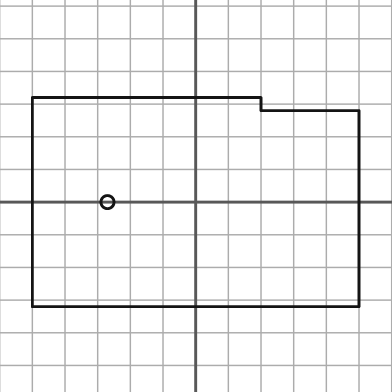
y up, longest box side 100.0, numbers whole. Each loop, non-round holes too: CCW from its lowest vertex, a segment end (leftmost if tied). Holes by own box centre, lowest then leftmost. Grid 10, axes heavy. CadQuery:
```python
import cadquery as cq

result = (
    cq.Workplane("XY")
    .moveTo(-50.0, -32.0)
    .lineTo(50.0, -32.0)
    .lineTo(50.0, 28.0)
    .lineTo(20.0, 28.0)
    .lineTo(20.0, 32.0)
    .lineTo(-50.0, 32.0)
    .close()
    .moveTo(-27.0, 0.0)
    .circle(2.0)
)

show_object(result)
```